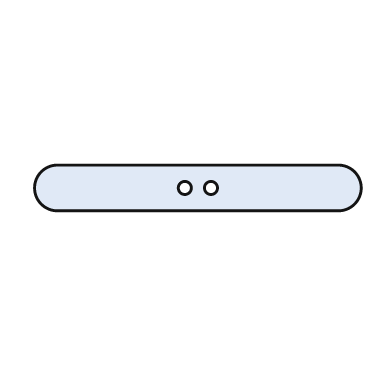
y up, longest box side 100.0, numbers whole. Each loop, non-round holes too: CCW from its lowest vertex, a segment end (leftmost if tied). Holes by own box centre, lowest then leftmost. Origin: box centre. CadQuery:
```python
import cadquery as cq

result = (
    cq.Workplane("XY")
    .moveTo(-43.0, -7.0)
    .lineTo(43.0, -7.0)
    .threePointArc((50.0, 0.0), (43.0, 7.0))
    .lineTo(-43.0, 7.0)
    .threePointArc((-50.0, 0.0), (-43.0, -7.0))
    .close()
    .moveTo(-4.0, 0.0)
    .circle(2.0)
    .moveTo(4.0, 0.0)
    .circle(2.0)
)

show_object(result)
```